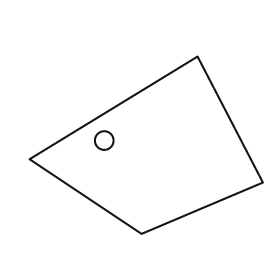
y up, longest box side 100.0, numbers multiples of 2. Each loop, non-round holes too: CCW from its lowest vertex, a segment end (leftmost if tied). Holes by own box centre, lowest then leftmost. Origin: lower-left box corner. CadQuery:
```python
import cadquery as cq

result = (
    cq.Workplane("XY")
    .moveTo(48.0, 0.0)
    .lineTo(100.0, 22.0)
    .lineTo(72.0, 76.0)
    .lineTo(0.0, 32.0)
    .close()
    .moveTo(32.0, 40.0)
    .circle(4.0)
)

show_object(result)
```